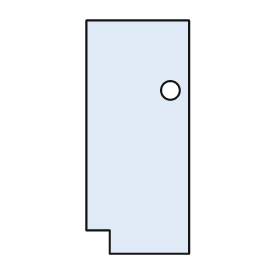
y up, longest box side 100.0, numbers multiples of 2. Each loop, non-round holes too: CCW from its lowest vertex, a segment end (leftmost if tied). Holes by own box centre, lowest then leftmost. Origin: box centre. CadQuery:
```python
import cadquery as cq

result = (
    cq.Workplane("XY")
    .moveTo(-12.0, -50.0)
    .lineTo(22.0, -50.0)
    .lineTo(22.0, 50.0)
    .lineTo(-22.0, 50.0)
    .lineTo(-22.0, -40.0)
    .lineTo(-12.0, -40.0)
    .close()
    .moveTo(14.0, 20.0)
    .circle(4.0)
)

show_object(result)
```